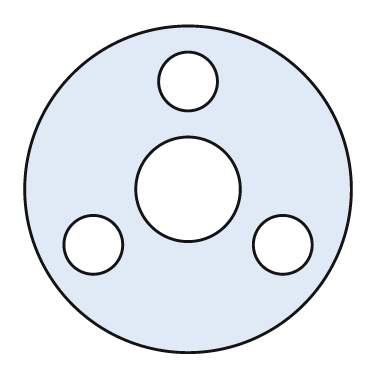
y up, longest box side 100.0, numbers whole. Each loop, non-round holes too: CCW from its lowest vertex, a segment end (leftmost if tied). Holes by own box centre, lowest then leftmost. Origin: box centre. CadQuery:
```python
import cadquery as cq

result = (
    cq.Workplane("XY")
    .moveTo(0.0, 0.0)
    .circle(50.0)
    .moveTo(-29.0, -17.0)
    .circle(9.0)
    .moveTo(29.0, -17.0)
    .circle(9.0)
    .moveTo(0.0, 0.0)
    .circle(16.0)
    .moveTo(0.0, 33.0)
    .circle(9.0)
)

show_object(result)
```